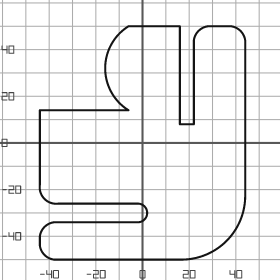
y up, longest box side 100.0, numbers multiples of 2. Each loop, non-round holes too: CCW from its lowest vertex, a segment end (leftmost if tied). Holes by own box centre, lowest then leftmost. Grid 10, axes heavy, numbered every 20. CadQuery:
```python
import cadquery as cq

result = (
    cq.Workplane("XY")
    .moveTo(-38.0, -50.0)
    .lineTo(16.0, -50.0)
    .threePointArc((36.0, -42.0), (44.0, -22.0))
    .lineTo(44.0, 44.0)
    .threePointArc((42.0, 48.0), (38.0, 50.0))
    .lineTo(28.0, 50.0)
    .threePointArc((24.0, 48.0), (22.0, 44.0))
    .lineTo(22.0, 8.0)
    .lineTo(16.0, 8.0)
    .lineTo(16.0, 50.0)
    .lineTo(-6.0, 50.0)
    .threePointArc((-16.0, 32.0), (-6.0, 14.0))
    .lineTo(-44.0, 14.0)
    .lineTo(-44.0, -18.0)
    .threePointArc((-42.0, -24.0), (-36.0, -26.0))
    .lineTo(-2.0, -26.0)
    .threePointArc((2.0, -30.0), (-2.0, -34.0))
    .lineTo(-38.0, -34.0)
    .threePointArc((-42.0, -36.0), (-44.0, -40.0))
    .lineTo(-44.0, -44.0)
    .threePointArc((-42.0, -48.0), (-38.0, -50.0))
    .close()
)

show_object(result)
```